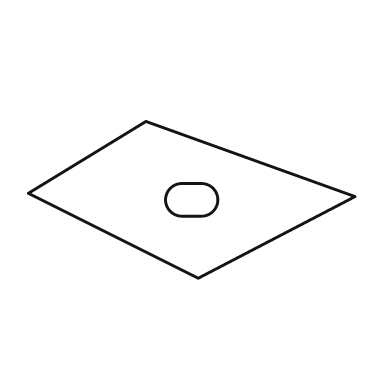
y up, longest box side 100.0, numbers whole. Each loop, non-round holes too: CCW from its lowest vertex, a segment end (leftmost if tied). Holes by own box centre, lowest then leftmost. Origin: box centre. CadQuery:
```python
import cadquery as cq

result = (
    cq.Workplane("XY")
    .moveTo(2.0, -24.0)
    .lineTo(50.0, 1.0)
    .lineTo(-14.0, 24.0)
    .lineTo(-50.0, 2.0)
    .close()
    .moveTo(-3.0, -5.0)
    .lineTo(3.0, -5.0)
    .threePointArc((8.0, 0.0), (3.0, 5.0))
    .lineTo(-3.0, 5.0)
    .threePointArc((-8.0, 0.0), (-3.0, -5.0))
    .close()
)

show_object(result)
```